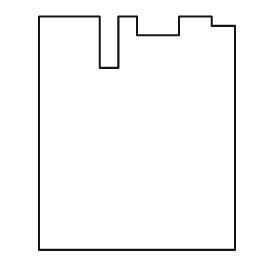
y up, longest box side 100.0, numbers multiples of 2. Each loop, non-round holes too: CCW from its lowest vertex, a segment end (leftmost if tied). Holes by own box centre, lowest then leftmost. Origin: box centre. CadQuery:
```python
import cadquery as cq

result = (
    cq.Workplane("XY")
    .moveTo(-42.0, -50.0)
    .lineTo(42.0, -50.0)
    .lineTo(42.0, 46.0)
    .lineTo(32.0, 46.0)
    .lineTo(32.0, 50.0)
    .lineTo(18.0, 50.0)
    .lineTo(18.0, 42.0)
    .lineTo(0.0, 42.0)
    .lineTo(0.0, 50.0)
    .lineTo(-8.0, 50.0)
    .lineTo(-8.0, 28.0)
    .lineTo(-16.0, 28.0)
    .lineTo(-16.0, 50.0)
    .lineTo(-42.0, 50.0)
    .close()
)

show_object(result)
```